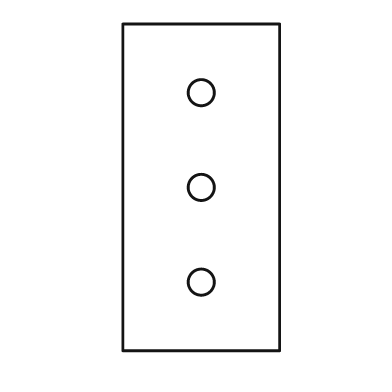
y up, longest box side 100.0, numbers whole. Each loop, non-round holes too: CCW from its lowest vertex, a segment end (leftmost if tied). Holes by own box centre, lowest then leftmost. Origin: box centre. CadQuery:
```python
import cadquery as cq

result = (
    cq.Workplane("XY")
    .moveTo(-24.0, -50.0)
    .lineTo(24.0, -50.0)
    .lineTo(24.0, 50.0)
    .lineTo(-24.0, 50.0)
    .close()
    .moveTo(0.0, -29.0)
    .circle(4.0)
    .moveTo(0.0, 0.0)
    .circle(4.0)
    .moveTo(0.0, 29.0)
    .circle(4.0)
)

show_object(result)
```